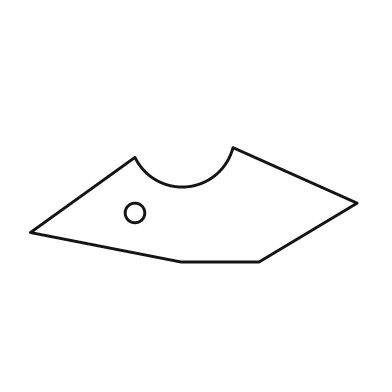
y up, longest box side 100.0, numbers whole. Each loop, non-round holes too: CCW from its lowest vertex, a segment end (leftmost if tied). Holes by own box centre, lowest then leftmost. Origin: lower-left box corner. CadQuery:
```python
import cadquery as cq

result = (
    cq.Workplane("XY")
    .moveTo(46.0, 0.0)
    .lineTo(70.0, 0.0)
    .lineTo(100.0, 18.0)
    .lineTo(62.0, 35.0)
    .threePointArc((48.0, 23.0), (32.0, 32.0))
    .lineTo(0.0, 9.0)
    .close()
    .moveTo(32.0, 15.0)
    .circle(3.0)
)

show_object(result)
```